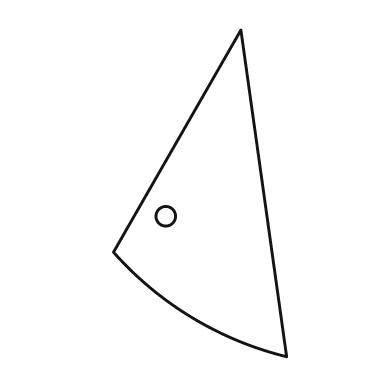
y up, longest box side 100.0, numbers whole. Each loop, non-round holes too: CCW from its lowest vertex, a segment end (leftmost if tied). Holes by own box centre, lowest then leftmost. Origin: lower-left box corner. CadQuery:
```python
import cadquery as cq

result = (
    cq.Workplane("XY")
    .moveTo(53.0, 0.0)
    .lineTo(39.0, 100.0)
    .lineTo(0.0, 32.0)
    .threePointArc((24.0, 12.0), (53.0, 0.0))
    .close()
    .moveTo(16.0, 43.0)
    .circle(3.0)
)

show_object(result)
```